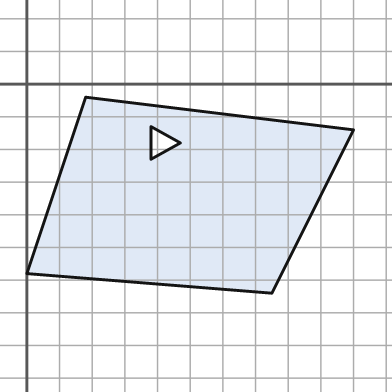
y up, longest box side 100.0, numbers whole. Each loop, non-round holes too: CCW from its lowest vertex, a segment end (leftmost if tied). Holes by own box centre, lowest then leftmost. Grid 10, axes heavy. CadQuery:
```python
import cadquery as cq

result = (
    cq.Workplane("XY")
    .moveTo(75.0, -64.0)
    .lineTo(100.0, -14.0)
    .lineTo(18.0, -4.0)
    .lineTo(0.0, -58.0)
    .close()
    .moveTo(38.0, -23.0)
    .lineTo(47.0, -18.0)
    .lineTo(38.0, -13.0)
    .close()
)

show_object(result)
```